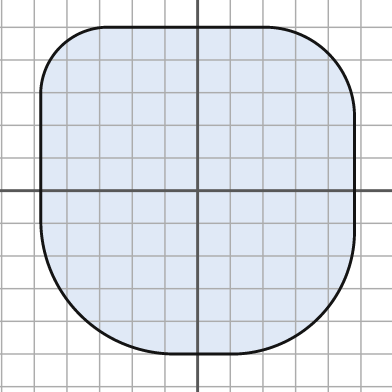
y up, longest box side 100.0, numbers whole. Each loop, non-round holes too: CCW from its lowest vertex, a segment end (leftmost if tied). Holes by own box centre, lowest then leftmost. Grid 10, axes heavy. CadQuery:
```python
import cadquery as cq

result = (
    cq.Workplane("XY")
    .moveTo(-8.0, -50.0)
    .lineTo(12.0, -50.0)
    .threePointArc((37.0, -39.0), (48.0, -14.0))
    .lineTo(48.0, 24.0)
    .threePointArc((40.0, 42.0), (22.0, 50.0))
    .lineTo(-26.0, 50.0)
    .threePointArc((-42.0, 44.0), (-48.0, 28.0))
    .lineTo(-48.0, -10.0)
    .threePointArc((-36.0, -38.0), (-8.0, -50.0))
    .close()
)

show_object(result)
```